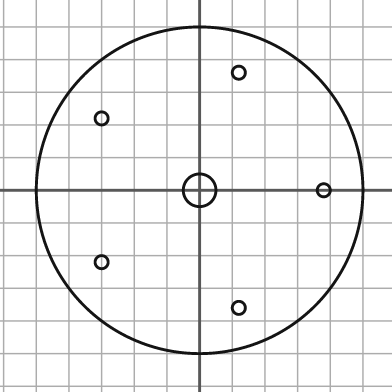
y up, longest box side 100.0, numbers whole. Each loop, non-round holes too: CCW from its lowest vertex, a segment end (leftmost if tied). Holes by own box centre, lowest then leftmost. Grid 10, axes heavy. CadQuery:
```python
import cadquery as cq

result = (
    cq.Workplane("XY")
    .moveTo(0.0, 0.0)
    .circle(50.0)
    .moveTo(12.0, -36.0)
    .circle(2.0)
    .moveTo(-30.0, -22.0)
    .circle(2.0)
    .moveTo(0.0, 0.0)
    .circle(5.0)
    .moveTo(38.0, 0.0)
    .circle(2.0)
    .moveTo(-30.0, 22.0)
    .circle(2.0)
    .moveTo(12.0, 36.0)
    .circle(2.0)
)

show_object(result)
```